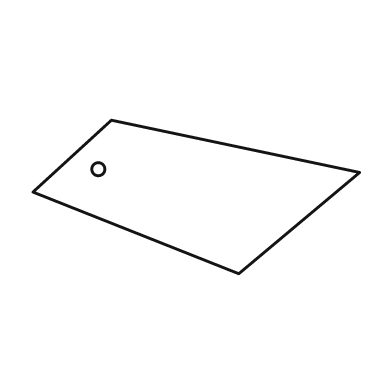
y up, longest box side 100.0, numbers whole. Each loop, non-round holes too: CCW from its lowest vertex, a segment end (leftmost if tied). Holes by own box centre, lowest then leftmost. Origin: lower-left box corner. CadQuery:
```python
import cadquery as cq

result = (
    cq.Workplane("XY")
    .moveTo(63.0, 0.0)
    .lineTo(100.0, 31.0)
    .lineTo(24.0, 47.0)
    .lineTo(0.0, 25.0)
    .close()
    .moveTo(20.0, 32.0)
    .circle(2.0)
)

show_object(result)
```